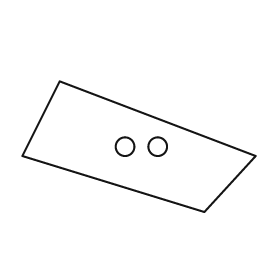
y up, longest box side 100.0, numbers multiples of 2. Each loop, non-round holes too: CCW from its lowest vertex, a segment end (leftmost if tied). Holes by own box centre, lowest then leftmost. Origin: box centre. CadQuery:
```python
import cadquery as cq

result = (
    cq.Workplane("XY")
    .moveTo(28.0, -28.0)
    .lineTo(50.0, -4.0)
    .lineTo(-34.0, 28.0)
    .lineTo(-50.0, -4.0)
    .close()
    .moveTo(-6.0, 0.0)
    .circle(4.0)
    .moveTo(8.0, 0.0)
    .circle(4.0)
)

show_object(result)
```